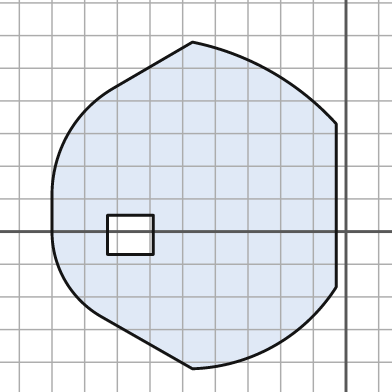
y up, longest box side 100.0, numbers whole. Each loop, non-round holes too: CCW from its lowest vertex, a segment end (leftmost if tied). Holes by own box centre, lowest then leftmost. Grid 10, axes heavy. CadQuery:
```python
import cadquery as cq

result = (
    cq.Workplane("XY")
    .moveTo(-47.0, -42.0)
    .threePointArc((-22.0, -35.0), (-3.0, -17.0))
    .lineTo(-3.0, 33.0)
    .threePointArc((-23.0, 49.0), (-47.0, 58.0))
    .lineTo(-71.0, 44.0)
    .threePointArc((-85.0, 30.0), (-90.0, 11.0))
    .lineTo(-90.0, 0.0)
    .threePointArc((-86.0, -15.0), (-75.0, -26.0))
    .close()
    .moveTo(-73.0, -7.0)
    .lineTo(-59.0, -7.0)
    .lineTo(-59.0, 5.0)
    .lineTo(-73.0, 5.0)
    .close()
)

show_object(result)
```